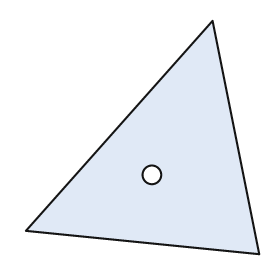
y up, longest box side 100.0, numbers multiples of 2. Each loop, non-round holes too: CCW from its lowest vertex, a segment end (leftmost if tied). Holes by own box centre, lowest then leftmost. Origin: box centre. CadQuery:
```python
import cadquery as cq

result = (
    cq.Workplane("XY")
    .moveTo(50.0, -50.0)
    .lineTo(30.0, 50.0)
    .lineTo(-50.0, -40.0)
    .close()
    .moveTo(4.0, -16.0)
    .circle(4.0)
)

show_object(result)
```